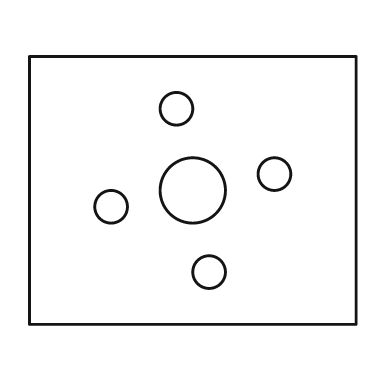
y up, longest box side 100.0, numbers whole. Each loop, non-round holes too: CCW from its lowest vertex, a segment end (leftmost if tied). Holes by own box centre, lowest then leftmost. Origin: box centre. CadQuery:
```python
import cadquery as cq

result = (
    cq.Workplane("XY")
    .moveTo(-50.0, -41.0)
    .lineTo(50.0, -41.0)
    .lineTo(50.0, 41.0)
    .lineTo(-50.0, 41.0)
    .close()
    .moveTo(5.0, -25.0)
    .circle(5.0)
    .moveTo(-25.0, -5.0)
    .circle(5.0)
    .moveTo(0.0, 0.0)
    .circle(10.0)
    .moveTo(25.0, 5.0)
    .circle(5.0)
    .moveTo(-5.0, 25.0)
    .circle(5.0)
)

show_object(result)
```